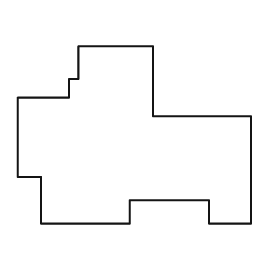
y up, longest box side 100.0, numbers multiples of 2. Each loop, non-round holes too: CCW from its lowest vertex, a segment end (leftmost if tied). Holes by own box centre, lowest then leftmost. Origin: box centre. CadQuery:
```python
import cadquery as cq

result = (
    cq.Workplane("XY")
    .moveTo(-40.0, -38.0)
    .lineTo(-2.0, -38.0)
    .lineTo(-2.0, -28.0)
    .lineTo(32.0, -28.0)
    .lineTo(32.0, -38.0)
    .lineTo(50.0, -38.0)
    .lineTo(50.0, 8.0)
    .lineTo(8.0, 8.0)
    .lineTo(8.0, 38.0)
    .lineTo(-24.0, 38.0)
    .lineTo(-24.0, 24.0)
    .lineTo(-28.0, 24.0)
    .lineTo(-28.0, 16.0)
    .lineTo(-50.0, 16.0)
    .lineTo(-50.0, -18.0)
    .lineTo(-40.0, -18.0)
    .close()
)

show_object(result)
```